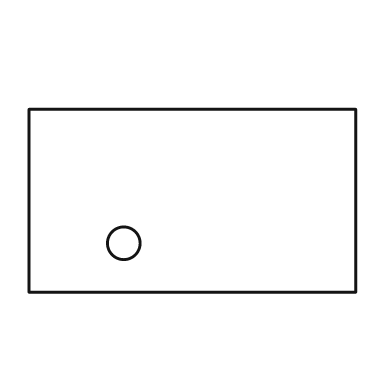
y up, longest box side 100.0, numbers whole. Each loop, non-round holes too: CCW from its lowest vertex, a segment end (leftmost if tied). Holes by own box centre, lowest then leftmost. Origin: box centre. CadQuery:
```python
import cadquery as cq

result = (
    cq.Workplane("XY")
    .moveTo(-50.0, -28.0)
    .lineTo(50.0, -28.0)
    .lineTo(50.0, 28.0)
    .lineTo(-50.0, 28.0)
    .close()
    .moveTo(-21.0, -13.0)
    .circle(5.0)
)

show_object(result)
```